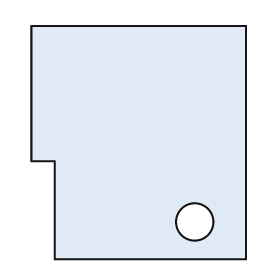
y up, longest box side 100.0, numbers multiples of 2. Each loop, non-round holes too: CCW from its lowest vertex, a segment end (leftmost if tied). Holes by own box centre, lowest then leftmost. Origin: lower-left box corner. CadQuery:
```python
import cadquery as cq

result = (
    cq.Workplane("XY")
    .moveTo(10.0, 0.0)
    .lineTo(92.0, 0.0)
    .lineTo(92.0, 100.0)
    .lineTo(0.0, 100.0)
    .lineTo(0.0, 42.0)
    .lineTo(10.0, 42.0)
    .close()
    .moveTo(70.0, 16.0)
    .circle(8.0)
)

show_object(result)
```